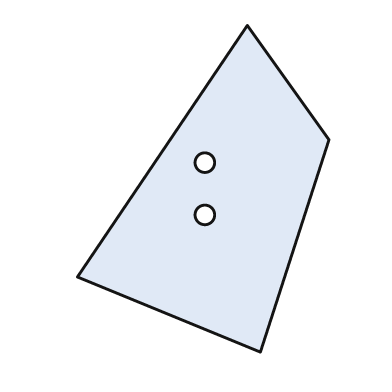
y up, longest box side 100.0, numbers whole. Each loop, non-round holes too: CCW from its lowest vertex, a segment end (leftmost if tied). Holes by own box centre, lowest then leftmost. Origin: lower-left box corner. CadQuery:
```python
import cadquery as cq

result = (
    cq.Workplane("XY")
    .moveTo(56.0, 0.0)
    .lineTo(77.0, 65.0)
    .lineTo(52.0, 100.0)
    .lineTo(0.0, 23.0)
    .close()
    .moveTo(39.0, 42.0)
    .circle(3.0)
    .moveTo(39.0, 58.0)
    .circle(3.0)
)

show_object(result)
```